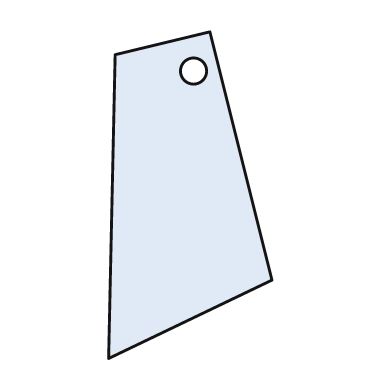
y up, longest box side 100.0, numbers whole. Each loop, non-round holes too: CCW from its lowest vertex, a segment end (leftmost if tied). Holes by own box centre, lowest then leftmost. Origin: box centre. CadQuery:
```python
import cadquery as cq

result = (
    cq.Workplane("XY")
    .moveTo(-25.0, -50.0)
    .lineTo(25.0, -26.0)
    .lineTo(6.0, 50.0)
    .lineTo(-23.0, 43.0)
    .close()
    .moveTo(1.0, 38.0)
    .circle(4.0)
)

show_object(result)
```